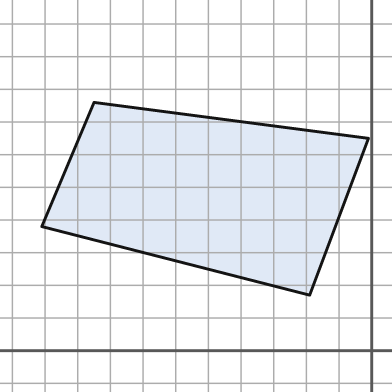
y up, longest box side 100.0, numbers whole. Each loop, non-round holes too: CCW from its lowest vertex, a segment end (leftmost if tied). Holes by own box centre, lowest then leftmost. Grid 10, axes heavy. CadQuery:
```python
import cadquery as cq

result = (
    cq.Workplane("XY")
    .moveTo(-19.0, 17.0)
    .lineTo(-1.0, 65.0)
    .lineTo(-85.0, 76.0)
    .lineTo(-101.0, 38.0)
    .close()
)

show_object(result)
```